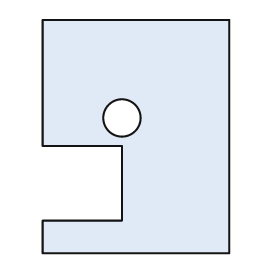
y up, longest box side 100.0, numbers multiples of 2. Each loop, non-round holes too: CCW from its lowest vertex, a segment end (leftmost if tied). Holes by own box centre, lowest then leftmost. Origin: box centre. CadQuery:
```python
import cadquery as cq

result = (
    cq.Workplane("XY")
    .moveTo(-40.0, -50.0)
    .lineTo(40.0, -50.0)
    .lineTo(40.0, 50.0)
    .lineTo(-40.0, 50.0)
    .lineTo(-40.0, -4.0)
    .lineTo(-6.0, -4.0)
    .lineTo(-6.0, -36.0)
    .lineTo(-40.0, -36.0)
    .close()
    .moveTo(-6.0, 8.0)
    .circle(8.0)
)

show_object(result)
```